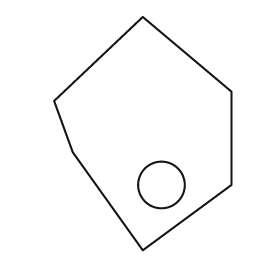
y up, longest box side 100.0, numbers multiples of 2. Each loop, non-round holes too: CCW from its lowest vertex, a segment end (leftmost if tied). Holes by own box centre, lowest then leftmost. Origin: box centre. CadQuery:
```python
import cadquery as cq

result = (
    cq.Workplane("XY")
    .moveTo(0.0, -50.0)
    .lineTo(38.0, -22.0)
    .lineTo(38.0, 18.0)
    .lineTo(0.0, 50.0)
    .lineTo(-38.0, 14.0)
    .lineTo(-30.0, -8.0)
    .close()
    .moveTo(8.0, -22.0)
    .circle(10.0)
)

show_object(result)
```